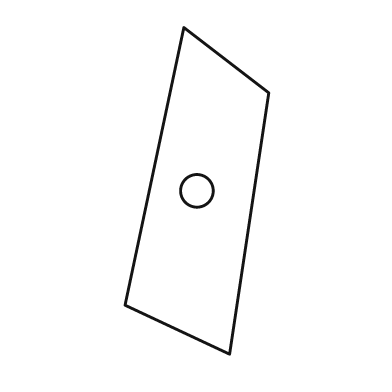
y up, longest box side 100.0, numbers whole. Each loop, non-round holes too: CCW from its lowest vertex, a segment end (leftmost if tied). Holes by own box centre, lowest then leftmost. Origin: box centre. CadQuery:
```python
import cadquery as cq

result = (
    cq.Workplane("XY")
    .moveTo(10.0, -50.0)
    .lineTo(22.0, 30.0)
    .lineTo(-4.0, 50.0)
    .lineTo(-22.0, -35.0)
    .close()
    .moveTo(0.0, 0.0)
    .circle(5.0)
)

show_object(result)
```